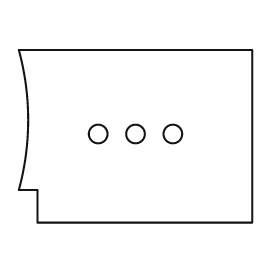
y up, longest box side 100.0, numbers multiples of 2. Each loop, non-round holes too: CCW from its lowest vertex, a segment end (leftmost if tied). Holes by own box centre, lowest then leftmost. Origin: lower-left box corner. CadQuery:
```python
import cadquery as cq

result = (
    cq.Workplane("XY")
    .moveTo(8.0, 0.0)
    .lineTo(100.0, 0.0)
    .lineTo(100.0, 74.0)
    .lineTo(0.0, 74.0)
    .threePointArc((4.0, 44.0), (0.0, 14.0))
    .lineTo(8.0, 14.0)
    .close()
    .moveTo(34.0, 38.0)
    .circle(4.0)
    .moveTo(50.0, 38.0)
    .circle(4.0)
    .moveTo(66.0, 38.0)
    .circle(4.0)
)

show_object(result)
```